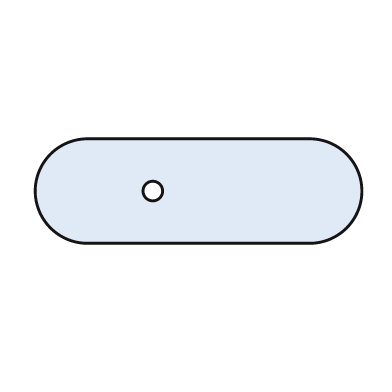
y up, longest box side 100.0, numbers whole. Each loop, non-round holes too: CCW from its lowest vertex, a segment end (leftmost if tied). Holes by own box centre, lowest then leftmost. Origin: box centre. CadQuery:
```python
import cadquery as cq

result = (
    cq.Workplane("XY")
    .moveTo(-34.0, -16.0)
    .lineTo(34.0, -16.0)
    .threePointArc((50.0, 0.0), (34.0, 16.0))
    .lineTo(-34.0, 16.0)
    .threePointArc((-50.0, 0.0), (-34.0, -16.0))
    .close()
    .moveTo(-14.0, 0.0)
    .circle(3.0)
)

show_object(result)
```